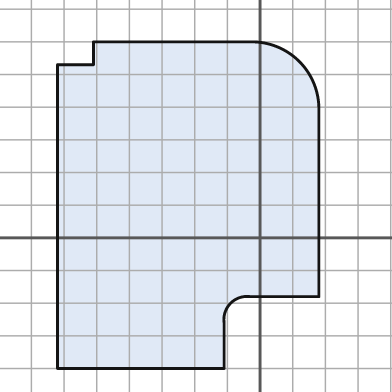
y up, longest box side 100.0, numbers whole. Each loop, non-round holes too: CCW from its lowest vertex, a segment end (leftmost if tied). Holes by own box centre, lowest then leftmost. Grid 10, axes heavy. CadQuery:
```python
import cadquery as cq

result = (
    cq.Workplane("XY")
    .moveTo(-62.0, -40.0)
    .lineTo(-11.0, -40.0)
    .lineTo(-11.0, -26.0)
    .threePointArc((-9.0, -20.0), (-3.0, -18.0))
    .lineTo(18.0, -18.0)
    .lineTo(18.0, 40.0)
    .threePointArc((12.0, 54.0), (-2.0, 60.0))
    .lineTo(-51.0, 60.0)
    .lineTo(-51.0, 53.0)
    .lineTo(-62.0, 53.0)
    .close()
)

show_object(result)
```